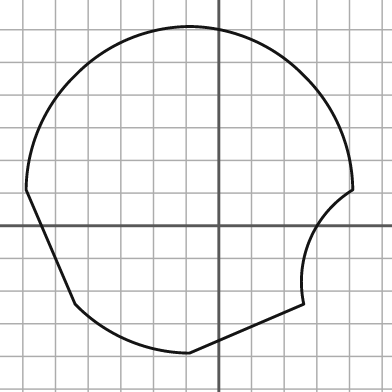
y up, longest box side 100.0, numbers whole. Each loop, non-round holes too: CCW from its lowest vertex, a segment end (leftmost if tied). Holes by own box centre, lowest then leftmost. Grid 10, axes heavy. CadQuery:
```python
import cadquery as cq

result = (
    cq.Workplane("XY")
    .moveTo(-9.0, -39.0)
    .lineTo(26.0, -24.0)
    .threePointArc((28.0, -4.0), (41.0, 11.0))
    .threePointArc((37.0, 30.0), (26.0, 46.0))
    .threePointArc((10.0, 57.0), (-9.0, 61.0))
    .threePointArc((-28.0, 57.0), (-44.0, 46.0))
    .threePointArc((-55.0, 30.0), (-59.0, 11.0))
    .lineTo(-44.0, -24.0)
    .threePointArc((-28.0, -35.0), (-9.0, -39.0))
    .close()
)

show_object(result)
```